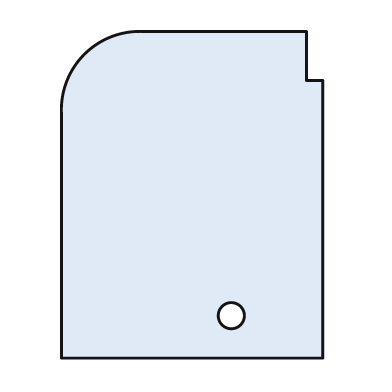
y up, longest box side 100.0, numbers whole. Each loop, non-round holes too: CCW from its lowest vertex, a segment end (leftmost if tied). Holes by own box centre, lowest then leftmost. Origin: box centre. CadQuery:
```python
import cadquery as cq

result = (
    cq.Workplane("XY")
    .moveTo(-40.0, -50.0)
    .lineTo(40.0, -50.0)
    .lineTo(40.0, 35.0)
    .lineTo(35.0, 35.0)
    .lineTo(35.0, 50.0)
    .lineTo(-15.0, 50.0)
    .threePointArc((-33.0, 43.0), (-40.0, 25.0))
    .close()
    .moveTo(12.0, -37.0)
    .circle(4.0)
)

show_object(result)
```